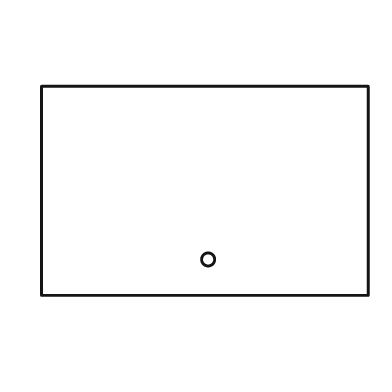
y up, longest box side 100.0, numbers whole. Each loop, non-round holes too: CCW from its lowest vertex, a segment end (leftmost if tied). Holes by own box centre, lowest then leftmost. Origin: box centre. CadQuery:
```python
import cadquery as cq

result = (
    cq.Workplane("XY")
    .moveTo(-50.0, -32.0)
    .lineTo(50.0, -32.0)
    .lineTo(50.0, 32.0)
    .lineTo(-50.0, 32.0)
    .close()
    .moveTo(1.0, -21.0)
    .circle(2.0)
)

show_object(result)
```